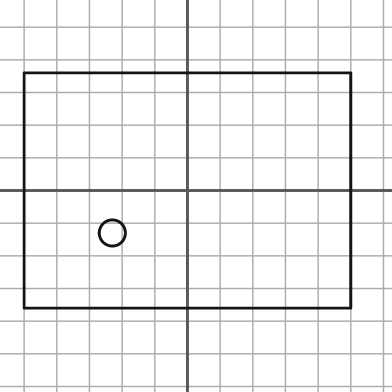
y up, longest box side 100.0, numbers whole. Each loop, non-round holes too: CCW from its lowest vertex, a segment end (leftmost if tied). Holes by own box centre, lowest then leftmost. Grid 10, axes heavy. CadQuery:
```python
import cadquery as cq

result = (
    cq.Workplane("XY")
    .moveTo(-50.0, -36.0)
    .lineTo(50.0, -36.0)
    .lineTo(50.0, 36.0)
    .lineTo(-50.0, 36.0)
    .close()
    .moveTo(-23.0, -13.0)
    .circle(4.0)
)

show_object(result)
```